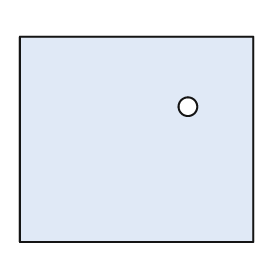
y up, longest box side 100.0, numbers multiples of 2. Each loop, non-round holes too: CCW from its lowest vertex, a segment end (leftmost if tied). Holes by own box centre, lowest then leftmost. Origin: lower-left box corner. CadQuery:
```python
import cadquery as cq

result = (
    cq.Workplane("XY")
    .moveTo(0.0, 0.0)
    .lineTo(100.0, 0.0)
    .lineTo(100.0, 88.0)
    .lineTo(0.0, 88.0)
    .close()
    .moveTo(72.0, 58.0)
    .circle(4.0)
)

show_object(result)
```